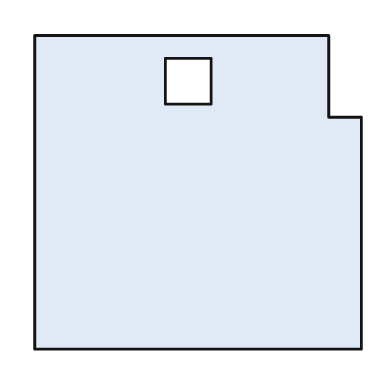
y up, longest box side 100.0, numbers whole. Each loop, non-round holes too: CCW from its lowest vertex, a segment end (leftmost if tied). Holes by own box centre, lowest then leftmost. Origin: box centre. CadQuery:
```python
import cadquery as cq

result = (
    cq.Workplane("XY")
    .moveTo(-50.0, -48.0)
    .lineTo(50.0, -48.0)
    .lineTo(50.0, 23.0)
    .lineTo(40.0, 23.0)
    .lineTo(40.0, 48.0)
    .lineTo(-50.0, 48.0)
    .close()
    .moveTo(-10.0, 27.0)
    .lineTo(4.0, 27.0)
    .lineTo(4.0, 41.0)
    .lineTo(-10.0, 41.0)
    .close()
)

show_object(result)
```